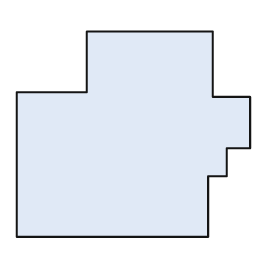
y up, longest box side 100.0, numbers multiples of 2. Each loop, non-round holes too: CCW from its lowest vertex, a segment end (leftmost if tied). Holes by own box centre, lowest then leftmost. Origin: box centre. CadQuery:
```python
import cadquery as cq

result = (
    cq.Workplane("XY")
    .moveTo(-50.0, -44.0)
    .lineTo(32.0, -44.0)
    .lineTo(32.0, -18.0)
    .lineTo(40.0, -18.0)
    .lineTo(40.0, -6.0)
    .lineTo(50.0, -6.0)
    .lineTo(50.0, 16.0)
    .lineTo(34.0, 16.0)
    .lineTo(34.0, 44.0)
    .lineTo(-20.0, 44.0)
    .lineTo(-20.0, 18.0)
    .lineTo(-50.0, 18.0)
    .close()
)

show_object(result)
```